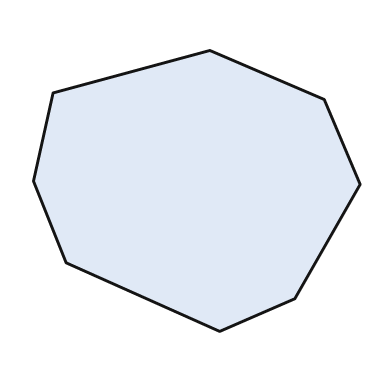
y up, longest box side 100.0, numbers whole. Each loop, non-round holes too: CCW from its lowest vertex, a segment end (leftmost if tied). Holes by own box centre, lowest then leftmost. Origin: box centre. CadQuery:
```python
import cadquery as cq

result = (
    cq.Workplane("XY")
    .moveTo(7.0, -43.0)
    .lineTo(30.0, -33.0)
    .lineTo(50.0, 2.0)
    .lineTo(39.0, 28.0)
    .lineTo(4.0, 43.0)
    .lineTo(-44.0, 30.0)
    .lineTo(-50.0, 3.0)
    .lineTo(-40.0, -22.0)
    .close()
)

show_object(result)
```